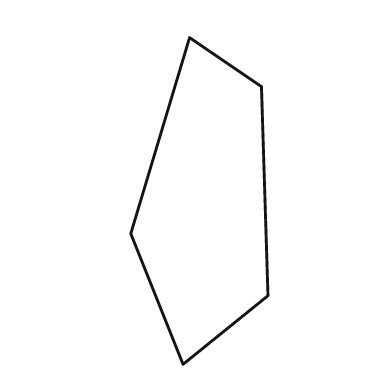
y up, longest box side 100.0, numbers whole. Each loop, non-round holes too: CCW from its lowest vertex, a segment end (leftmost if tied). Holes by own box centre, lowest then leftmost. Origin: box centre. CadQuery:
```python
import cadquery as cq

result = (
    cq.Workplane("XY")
    .moveTo(-5.0, -50.0)
    .lineTo(21.0, -29.0)
    .lineTo(19.0, 35.0)
    .lineTo(-3.0, 50.0)
    .lineTo(-21.0, -10.0)
    .close()
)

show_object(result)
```